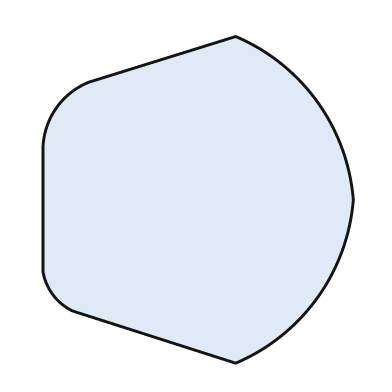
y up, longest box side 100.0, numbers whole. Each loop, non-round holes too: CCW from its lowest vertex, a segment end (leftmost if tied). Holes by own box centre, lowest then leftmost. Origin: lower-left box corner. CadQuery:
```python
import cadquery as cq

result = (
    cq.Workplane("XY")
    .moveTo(59.0, 0.0)
    .threePointArc((84.0, 20.0), (95.0, 50.0))
    .threePointArc((84.0, 80.0), (59.0, 100.0))
    .lineTo(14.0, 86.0)
    .threePointArc((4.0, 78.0), (0.0, 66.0))
    .lineTo(0.0, 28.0)
    .threePointArc((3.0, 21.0), (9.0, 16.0))
    .close()
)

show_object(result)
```